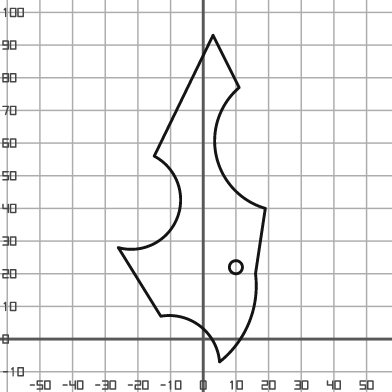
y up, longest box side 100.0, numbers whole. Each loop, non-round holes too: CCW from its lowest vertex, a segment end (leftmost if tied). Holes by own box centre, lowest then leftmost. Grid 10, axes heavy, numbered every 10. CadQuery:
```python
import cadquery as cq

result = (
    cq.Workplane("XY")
    .moveTo(5.0, -7.0)
    .threePointArc((14.0, 5.0), (16.0, 20.0))
    .lineTo(19.0, 40.0)
    .threePointArc((4.0, 56.0), (11.0, 77.0))
    .lineTo(3.0, 93.0)
    .lineTo(-15.0, 56.0)
    .threePointArc((-8.0, 37.0), (-26.0, 28.0))
    .lineTo(-13.0, 7.0)
    .threePointArc((-1.0, 4.0), (5.0, -7.0))
    .close()
    .moveTo(10.0, 22.0)
    .circle(2.0)
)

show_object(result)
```